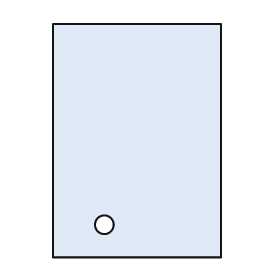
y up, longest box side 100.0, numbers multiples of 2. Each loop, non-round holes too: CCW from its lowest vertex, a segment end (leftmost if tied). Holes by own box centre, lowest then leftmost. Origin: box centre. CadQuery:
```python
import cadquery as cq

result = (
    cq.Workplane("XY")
    .moveTo(-36.0, -50.0)
    .lineTo(36.0, -50.0)
    .lineTo(36.0, 50.0)
    .lineTo(-36.0, 50.0)
    .close()
    .moveTo(-14.0, -36.0)
    .circle(4.0)
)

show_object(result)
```